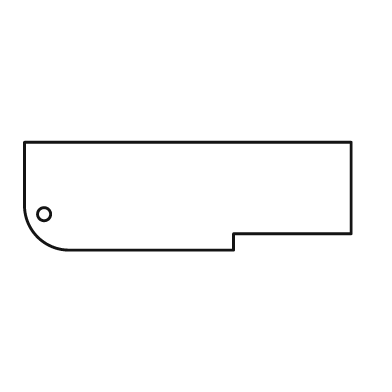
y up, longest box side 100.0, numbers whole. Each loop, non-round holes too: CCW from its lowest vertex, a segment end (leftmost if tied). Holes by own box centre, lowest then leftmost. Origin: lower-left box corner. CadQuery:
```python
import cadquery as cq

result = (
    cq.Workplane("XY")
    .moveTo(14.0, 0.0)
    .lineTo(64.0, 0.0)
    .lineTo(64.0, 5.0)
    .lineTo(100.0, 5.0)
    .lineTo(100.0, 33.0)
    .lineTo(0.0, 33.0)
    .lineTo(0.0, 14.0)
    .threePointArc((4.0, 4.0), (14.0, 0.0))
    .close()
    .moveTo(6.0, 11.0)
    .circle(2.0)
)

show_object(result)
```